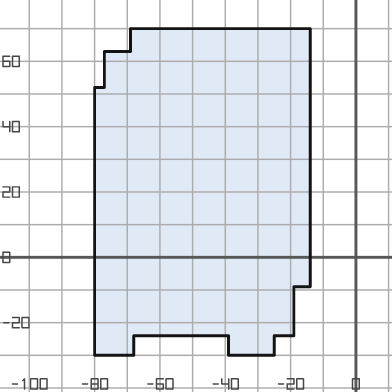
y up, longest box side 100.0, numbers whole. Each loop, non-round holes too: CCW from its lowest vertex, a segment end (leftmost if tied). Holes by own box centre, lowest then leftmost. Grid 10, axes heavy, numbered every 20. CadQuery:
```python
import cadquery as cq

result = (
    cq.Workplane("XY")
    .moveTo(-80.0, -30.0)
    .lineTo(-68.0, -30.0)
    .lineTo(-68.0, -24.0)
    .lineTo(-39.0, -24.0)
    .lineTo(-39.0, -30.0)
    .lineTo(-25.0, -30.0)
    .lineTo(-25.0, -24.0)
    .lineTo(-19.0, -24.0)
    .lineTo(-19.0, -9.0)
    .lineTo(-14.0, -9.0)
    .lineTo(-14.0, 70.0)
    .lineTo(-69.0, 70.0)
    .lineTo(-69.0, 63.0)
    .lineTo(-77.0, 63.0)
    .lineTo(-77.0, 52.0)
    .lineTo(-80.0, 52.0)
    .close()
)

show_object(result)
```